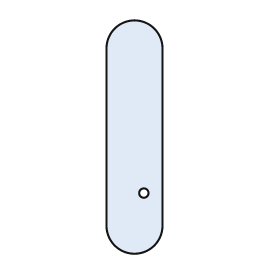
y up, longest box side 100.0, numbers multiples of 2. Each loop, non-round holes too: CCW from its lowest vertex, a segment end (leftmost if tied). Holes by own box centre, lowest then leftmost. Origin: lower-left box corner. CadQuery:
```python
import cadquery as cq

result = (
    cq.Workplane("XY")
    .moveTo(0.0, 12.0)
    .threePointArc((12.0, 0.0), (24.0, 12.0))
    .lineTo(24.0, 88.0)
    .threePointArc((12.0, 100.0), (0.0, 88.0))
    .close()
    .moveTo(16.0, 26.0)
    .circle(2.0)
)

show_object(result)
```